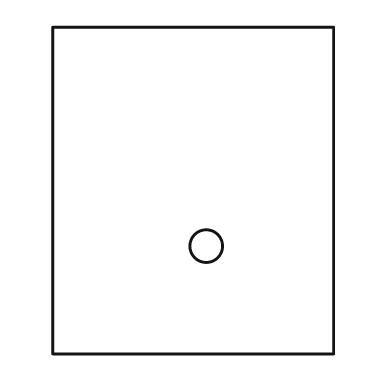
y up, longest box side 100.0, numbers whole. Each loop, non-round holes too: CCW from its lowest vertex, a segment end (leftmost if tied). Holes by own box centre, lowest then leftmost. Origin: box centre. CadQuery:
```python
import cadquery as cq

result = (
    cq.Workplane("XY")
    .moveTo(-43.0, -50.0)
    .lineTo(43.0, -50.0)
    .lineTo(43.0, 50.0)
    .lineTo(-43.0, 50.0)
    .close()
    .moveTo(4.0, -17.0)
    .circle(5.0)
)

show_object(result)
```